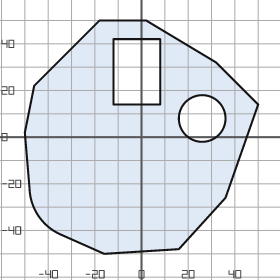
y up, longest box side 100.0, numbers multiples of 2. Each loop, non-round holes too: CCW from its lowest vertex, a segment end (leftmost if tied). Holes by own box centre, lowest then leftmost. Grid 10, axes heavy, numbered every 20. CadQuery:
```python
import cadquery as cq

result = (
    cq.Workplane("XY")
    .moveTo(-16.0, -50.0)
    .lineTo(16.0, -48.0)
    .lineTo(36.0, -26.0)
    .lineTo(50.0, 14.0)
    .lineTo(32.0, 32.0)
    .lineTo(2.0, 50.0)
    .lineTo(-18.0, 50.0)
    .lineTo(-46.0, 22.0)
    .lineTo(-50.0, 2.0)
    .lineTo(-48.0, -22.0)
    .threePointArc((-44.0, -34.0), (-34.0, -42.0))
    .close()
    .moveTo(26.0, 8.0)
    .circle(10.0)
    .moveTo(-12.0, 14.0)
    .lineTo(8.0, 14.0)
    .lineTo(8.0, 42.0)
    .lineTo(-12.0, 42.0)
    .close()
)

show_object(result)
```